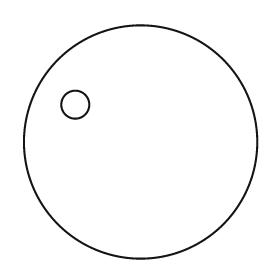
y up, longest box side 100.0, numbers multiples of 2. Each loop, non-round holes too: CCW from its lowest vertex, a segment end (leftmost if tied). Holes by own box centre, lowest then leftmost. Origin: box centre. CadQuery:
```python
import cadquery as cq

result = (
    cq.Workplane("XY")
    .moveTo(0.0, 0.0)
    .circle(50.0)
    .moveTo(-28.0, 16.0)
    .circle(6.0)
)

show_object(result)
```